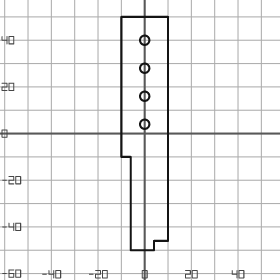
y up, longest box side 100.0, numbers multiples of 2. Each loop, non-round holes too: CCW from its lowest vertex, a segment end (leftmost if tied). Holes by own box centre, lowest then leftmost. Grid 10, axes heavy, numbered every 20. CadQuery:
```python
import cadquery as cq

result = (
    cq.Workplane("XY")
    .moveTo(-6.0, -50.0)
    .lineTo(4.0, -50.0)
    .lineTo(4.0, -46.0)
    .lineTo(10.0, -46.0)
    .lineTo(10.0, 50.0)
    .lineTo(-10.0, 50.0)
    .lineTo(-10.0, -10.0)
    .lineTo(-6.0, -10.0)
    .close()
    .moveTo(0.0, 4.0)
    .circle(2.0)
    .moveTo(0.0, 16.0)
    .circle(2.0)
    .moveTo(0.0, 28.0)
    .circle(2.0)
    .moveTo(0.0, 40.0)
    .circle(2.0)
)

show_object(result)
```